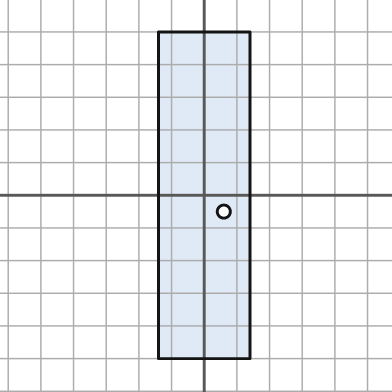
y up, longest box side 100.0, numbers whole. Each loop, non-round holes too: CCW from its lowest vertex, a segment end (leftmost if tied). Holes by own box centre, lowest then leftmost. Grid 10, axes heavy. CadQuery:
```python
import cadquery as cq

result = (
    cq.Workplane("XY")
    .moveTo(-14.0, -50.0)
    .lineTo(14.0, -50.0)
    .lineTo(14.0, 50.0)
    .lineTo(-14.0, 50.0)
    .close()
    .moveTo(6.0, -5.0)
    .circle(2.0)
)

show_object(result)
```